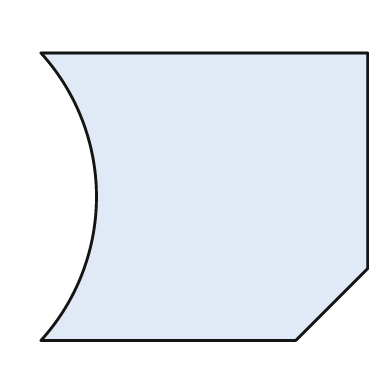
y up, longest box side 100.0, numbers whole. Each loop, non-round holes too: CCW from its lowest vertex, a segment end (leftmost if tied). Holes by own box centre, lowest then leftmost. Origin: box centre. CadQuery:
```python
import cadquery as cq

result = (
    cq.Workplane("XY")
    .moveTo(-50.0, -44.0)
    .lineTo(28.0, -44.0)
    .lineTo(50.0, -22.0)
    .lineTo(50.0, 44.0)
    .lineTo(-50.0, 44.0)
    .threePointArc((-33.0, 0.0), (-50.0, -44.0))
    .close()
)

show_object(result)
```